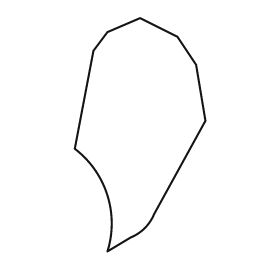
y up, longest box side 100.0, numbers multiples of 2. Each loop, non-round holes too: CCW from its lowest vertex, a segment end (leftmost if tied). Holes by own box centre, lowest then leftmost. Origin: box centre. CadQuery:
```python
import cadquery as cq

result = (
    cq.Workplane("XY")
    .moveTo(-14.0, -50.0)
    .lineTo(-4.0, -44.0)
    .threePointArc((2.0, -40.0), (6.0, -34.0))
    .lineTo(28.0, 6.0)
    .lineTo(24.0, 30.0)
    .lineTo(16.0, 42.0)
    .lineTo(0.0, 50.0)
    .lineTo(-14.0, 44.0)
    .lineTo(-20.0, 36.0)
    .lineTo(-28.0, -6.0)
    .threePointArc((-14.0, -26.0), (-14.0, -50.0))
    .close()
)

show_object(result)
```